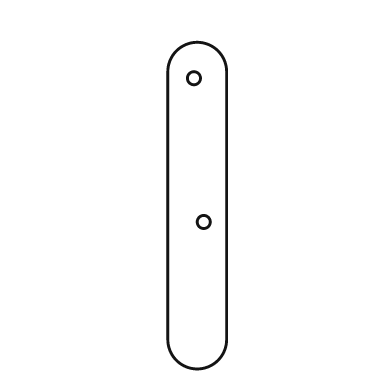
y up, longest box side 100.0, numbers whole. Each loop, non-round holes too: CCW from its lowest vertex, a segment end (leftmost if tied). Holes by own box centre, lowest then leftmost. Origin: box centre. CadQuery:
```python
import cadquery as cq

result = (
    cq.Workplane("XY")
    .moveTo(-9.0, -41.0)
    .threePointArc((0.0, -50.0), (9.0, -41.0))
    .lineTo(9.0, 41.0)
    .threePointArc((0.0, 50.0), (-9.0, 41.0))
    .close()
    .moveTo(2.0, -5.0)
    .circle(2.0)
    .moveTo(-1.0, 39.0)
    .circle(2.0)
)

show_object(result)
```